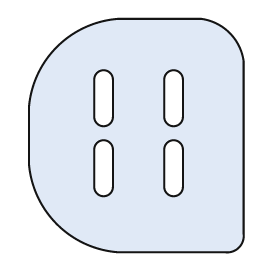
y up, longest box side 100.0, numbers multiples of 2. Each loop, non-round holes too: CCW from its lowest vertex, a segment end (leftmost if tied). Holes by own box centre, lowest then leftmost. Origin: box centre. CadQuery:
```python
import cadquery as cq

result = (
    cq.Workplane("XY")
    .moveTo(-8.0, -50.0)
    .lineTo(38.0, -50.0)
    .threePointArc((44.0, -48.0), (46.0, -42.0))
    .lineTo(46.0, 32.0)
    .threePointArc((40.0, 44.0), (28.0, 50.0))
    .lineTo(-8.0, 50.0)
    .threePointArc((-34.0, 38.0), (-46.0, 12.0))
    .lineTo(-46.0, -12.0)
    .threePointArc((-34.0, -38.0), (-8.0, -50.0))
    .close()
    .moveTo(-18.0, -22.0)
    .threePointArc((-14.0, -26.0), (-10.0, -22.0))
    .lineTo(-10.0, -6.0)
    .threePointArc((-14.0, -2.0), (-18.0, -6.0))
    .close()
    .moveTo(12.0, -22.0)
    .threePointArc((16.0, -26.0), (20.0, -22.0))
    .lineTo(20.0, -6.0)
    .threePointArc((16.0, -2.0), (12.0, -6.0))
    .close()
    .moveTo(-18.0, 8.0)
    .threePointArc((-14.0, 4.0), (-10.0, 8.0))
    .lineTo(-10.0, 24.0)
    .threePointArc((-14.0, 28.0), (-18.0, 24.0))
    .close()
    .moveTo(12.0, 8.0)
    .threePointArc((16.0, 4.0), (20.0, 8.0))
    .lineTo(20.0, 24.0)
    .threePointArc((16.0, 28.0), (12.0, 24.0))
    .close()
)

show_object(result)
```